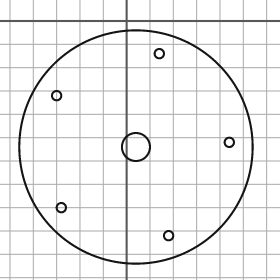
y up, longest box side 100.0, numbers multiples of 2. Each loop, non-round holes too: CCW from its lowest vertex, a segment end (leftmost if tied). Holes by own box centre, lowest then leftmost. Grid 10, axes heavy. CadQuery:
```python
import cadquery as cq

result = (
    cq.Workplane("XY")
    .moveTo(4.0, -54.0)
    .circle(50.0)
    .moveTo(18.0, -92.0)
    .circle(2.0)
    .moveTo(-28.0, -80.0)
    .circle(2.0)
    .moveTo(4.0, -54.0)
    .circle(6.0)
    .moveTo(44.0, -52.0)
    .circle(2.0)
    .moveTo(-30.0, -32.0)
    .circle(2.0)
    .moveTo(14.0, -14.0)
    .circle(2.0)
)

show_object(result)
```